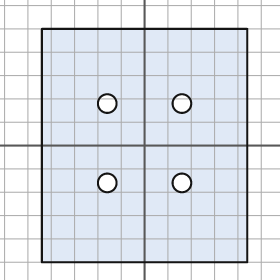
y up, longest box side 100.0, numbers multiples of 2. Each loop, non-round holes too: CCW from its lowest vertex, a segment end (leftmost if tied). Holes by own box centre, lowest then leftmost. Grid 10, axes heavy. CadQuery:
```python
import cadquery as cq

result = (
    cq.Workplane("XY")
    .moveTo(-44.0, -50.0)
    .lineTo(44.0, -50.0)
    .lineTo(44.0, 50.0)
    .lineTo(-44.0, 50.0)
    .close()
    .moveTo(-16.0, -16.0)
    .circle(4.0)
    .moveTo(16.0, -16.0)
    .circle(4.0)
    .moveTo(-16.0, 18.0)
    .circle(4.0)
    .moveTo(16.0, 18.0)
    .circle(4.0)
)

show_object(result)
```